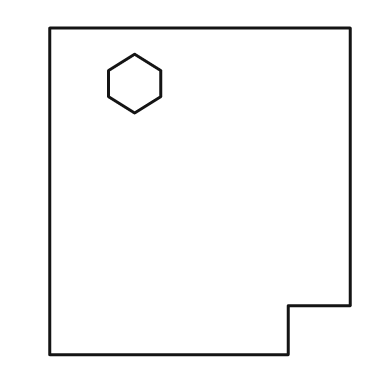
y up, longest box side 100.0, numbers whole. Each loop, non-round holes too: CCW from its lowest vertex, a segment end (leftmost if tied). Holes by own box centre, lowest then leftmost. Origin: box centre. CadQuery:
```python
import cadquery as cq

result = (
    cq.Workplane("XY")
    .moveTo(-46.0, -50.0)
    .lineTo(27.0, -50.0)
    .lineTo(27.0, -35.0)
    .lineTo(46.0, -35.0)
    .lineTo(46.0, 50.0)
    .lineTo(-46.0, 50.0)
    .close()
    .moveTo(-20.0, 24.0)
    .lineTo(-12.0, 29.0)
    .lineTo(-12.0, 37.0)
    .lineTo(-20.0, 42.0)
    .lineTo(-28.0, 37.0)
    .lineTo(-28.0, 29.0)
    .close()
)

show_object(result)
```